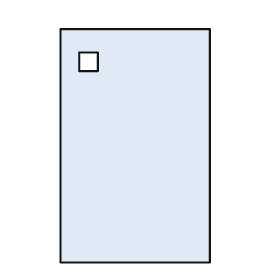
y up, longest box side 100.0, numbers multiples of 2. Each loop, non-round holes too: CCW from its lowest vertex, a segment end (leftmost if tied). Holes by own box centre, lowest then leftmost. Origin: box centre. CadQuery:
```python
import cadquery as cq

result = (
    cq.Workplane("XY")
    .moveTo(-32.0, -50.0)
    .lineTo(32.0, -50.0)
    .lineTo(32.0, 50.0)
    .lineTo(-32.0, 50.0)
    .close()
    .moveTo(-24.0, 32.0)
    .lineTo(-16.0, 32.0)
    .lineTo(-16.0, 40.0)
    .lineTo(-24.0, 40.0)
    .close()
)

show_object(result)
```